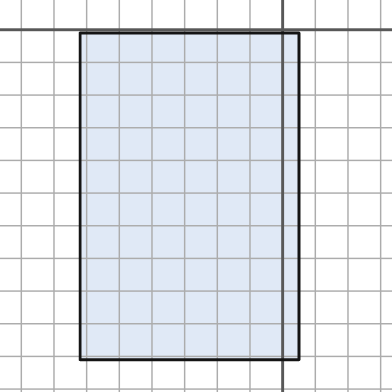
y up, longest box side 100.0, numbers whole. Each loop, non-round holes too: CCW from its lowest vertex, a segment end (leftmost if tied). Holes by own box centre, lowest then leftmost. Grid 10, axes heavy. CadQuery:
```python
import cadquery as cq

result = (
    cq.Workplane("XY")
    .moveTo(-62.0, -101.0)
    .lineTo(5.0, -101.0)
    .lineTo(5.0, -1.0)
    .lineTo(-62.0, -1.0)
    .close()
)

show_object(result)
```